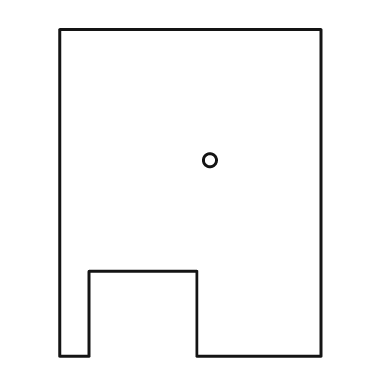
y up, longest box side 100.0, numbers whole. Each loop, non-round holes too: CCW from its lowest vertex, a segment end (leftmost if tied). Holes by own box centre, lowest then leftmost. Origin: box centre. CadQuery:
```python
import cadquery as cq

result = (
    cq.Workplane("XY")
    .moveTo(-40.0, -50.0)
    .lineTo(-31.0, -50.0)
    .lineTo(-31.0, -24.0)
    .lineTo(2.0, -24.0)
    .lineTo(2.0, -50.0)
    .lineTo(40.0, -50.0)
    .lineTo(40.0, 50.0)
    .lineTo(-40.0, 50.0)
    .close()
    .moveTo(6.0, 10.0)
    .circle(2.0)
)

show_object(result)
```